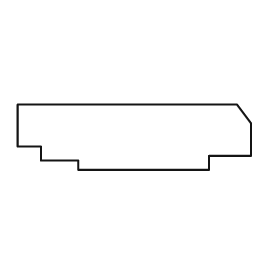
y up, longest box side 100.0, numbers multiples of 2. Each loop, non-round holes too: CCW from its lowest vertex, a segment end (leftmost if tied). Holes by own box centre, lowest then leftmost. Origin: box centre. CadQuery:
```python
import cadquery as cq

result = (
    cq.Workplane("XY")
    .moveTo(-24.0, -14.0)
    .lineTo(32.0, -14.0)
    .lineTo(32.0, -8.0)
    .lineTo(50.0, -8.0)
    .lineTo(50.0, 6.0)
    .lineTo(44.0, 14.0)
    .lineTo(-50.0, 14.0)
    .lineTo(-50.0, -4.0)
    .lineTo(-40.0, -4.0)
    .lineTo(-40.0, -10.0)
    .lineTo(-24.0, -10.0)
    .close()
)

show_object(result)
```